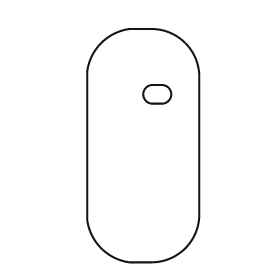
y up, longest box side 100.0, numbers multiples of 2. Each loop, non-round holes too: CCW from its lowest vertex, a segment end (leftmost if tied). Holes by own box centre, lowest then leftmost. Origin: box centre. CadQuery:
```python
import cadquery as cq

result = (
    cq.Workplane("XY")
    .moveTo(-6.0, -50.0)
    .lineTo(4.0, -50.0)
    .threePointArc((18.0, -44.0), (24.0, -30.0))
    .lineTo(24.0, 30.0)
    .threePointArc((18.0, 44.0), (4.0, 50.0))
    .lineTo(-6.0, 50.0)
    .threePointArc((-18.0, 44.0), (-24.0, 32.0))
    .lineTo(-24.0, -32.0)
    .threePointArc((-18.0, -44.0), (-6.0, -50.0))
    .close()
    .moveTo(4.0, 18.0)
    .lineTo(8.0, 18.0)
    .threePointArc((12.0, 22.0), (8.0, 26.0))
    .lineTo(4.0, 26.0)
    .threePointArc((0.0, 22.0), (4.0, 18.0))
    .close()
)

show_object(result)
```